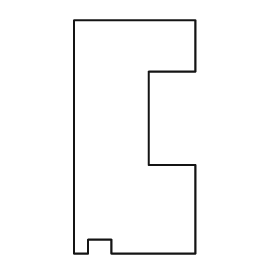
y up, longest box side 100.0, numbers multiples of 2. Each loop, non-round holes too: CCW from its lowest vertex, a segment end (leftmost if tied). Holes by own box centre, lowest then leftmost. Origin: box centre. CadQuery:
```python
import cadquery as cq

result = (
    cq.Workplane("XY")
    .moveTo(-26.0, -50.0)
    .lineTo(-20.0, -50.0)
    .lineTo(-20.0, -44.0)
    .lineTo(-10.0, -44.0)
    .lineTo(-10.0, -50.0)
    .lineTo(26.0, -50.0)
    .lineTo(26.0, -12.0)
    .lineTo(6.0, -12.0)
    .lineTo(6.0, 28.0)
    .lineTo(26.0, 28.0)
    .lineTo(26.0, 50.0)
    .lineTo(-26.0, 50.0)
    .close()
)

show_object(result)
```